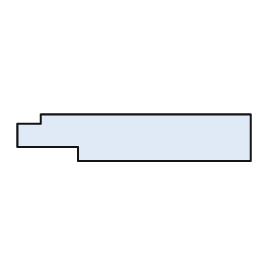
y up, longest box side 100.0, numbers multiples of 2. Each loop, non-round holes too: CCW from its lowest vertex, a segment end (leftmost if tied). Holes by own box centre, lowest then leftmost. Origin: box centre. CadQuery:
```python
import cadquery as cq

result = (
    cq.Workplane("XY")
    .moveTo(-24.0, -10.0)
    .lineTo(50.0, -10.0)
    .lineTo(50.0, 10.0)
    .lineTo(-40.0, 10.0)
    .lineTo(-40.0, 6.0)
    .lineTo(-50.0, 6.0)
    .lineTo(-50.0, -4.0)
    .lineTo(-24.0, -4.0)
    .close()
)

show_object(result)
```